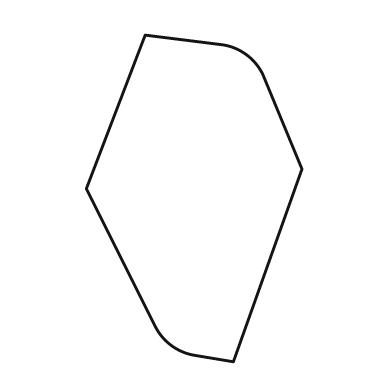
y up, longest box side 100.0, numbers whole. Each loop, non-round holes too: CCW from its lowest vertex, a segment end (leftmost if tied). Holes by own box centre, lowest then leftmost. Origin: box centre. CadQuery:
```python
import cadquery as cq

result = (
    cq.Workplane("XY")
    .moveTo(12.0, -50.0)
    .lineTo(33.0, 9.0)
    .lineTo(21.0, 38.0)
    .threePointArc((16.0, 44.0), (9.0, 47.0))
    .lineTo(-15.0, 50.0)
    .lineTo(-33.0, 3.0)
    .lineTo(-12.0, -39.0)
    .threePointArc((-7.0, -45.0), (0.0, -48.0))
    .close()
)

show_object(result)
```